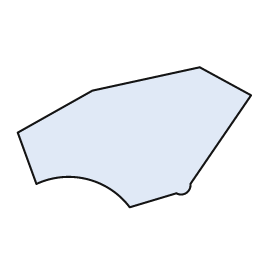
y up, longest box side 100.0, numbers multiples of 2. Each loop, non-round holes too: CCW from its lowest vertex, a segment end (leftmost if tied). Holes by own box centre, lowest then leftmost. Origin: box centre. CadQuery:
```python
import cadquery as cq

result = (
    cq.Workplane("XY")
    .moveTo(-2.0, -30.0)
    .lineTo(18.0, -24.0)
    .threePointArc((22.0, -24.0), (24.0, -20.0))
    .lineTo(50.0, 18.0)
    .lineTo(28.0, 30.0)
    .lineTo(-18.0, 20.0)
    .lineTo(-50.0, 2.0)
    .lineTo(-42.0, -20.0)
    .threePointArc((-20.0, -18.0), (-2.0, -30.0))
    .close()
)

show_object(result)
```